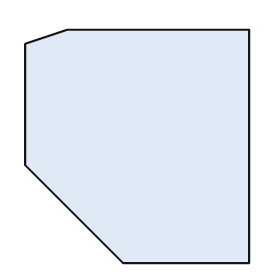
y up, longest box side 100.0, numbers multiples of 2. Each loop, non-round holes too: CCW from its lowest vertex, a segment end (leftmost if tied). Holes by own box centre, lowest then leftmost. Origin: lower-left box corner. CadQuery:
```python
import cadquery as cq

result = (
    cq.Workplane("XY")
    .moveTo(42.0, 0.0)
    .lineTo(96.0, 0.0)
    .lineTo(96.0, 100.0)
    .lineTo(18.0, 100.0)
    .lineTo(0.0, 94.0)
    .lineTo(0.0, 42.0)
    .close()
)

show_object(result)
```